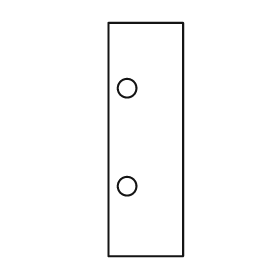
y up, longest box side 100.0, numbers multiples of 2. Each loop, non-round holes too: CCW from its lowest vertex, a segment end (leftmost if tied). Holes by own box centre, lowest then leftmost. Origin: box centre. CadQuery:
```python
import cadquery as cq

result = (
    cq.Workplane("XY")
    .moveTo(-16.0, -50.0)
    .lineTo(16.0, -50.0)
    .lineTo(16.0, 50.0)
    .lineTo(-16.0, 50.0)
    .close()
    .moveTo(-8.0, -20.0)
    .circle(4.0)
    .moveTo(-8.0, 22.0)
    .circle(4.0)
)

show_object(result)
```